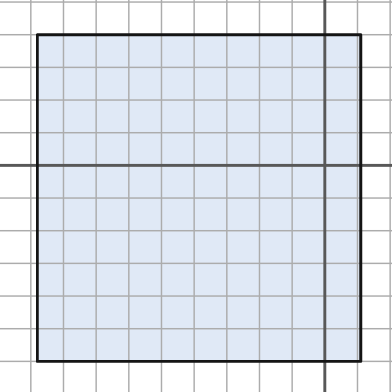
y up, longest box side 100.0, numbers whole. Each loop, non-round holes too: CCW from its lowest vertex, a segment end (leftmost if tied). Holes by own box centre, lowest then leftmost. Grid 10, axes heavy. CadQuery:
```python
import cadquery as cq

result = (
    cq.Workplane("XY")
    .moveTo(-88.0, -60.0)
    .lineTo(11.0, -60.0)
    .lineTo(11.0, 40.0)
    .lineTo(-88.0, 40.0)
    .close()
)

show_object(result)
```